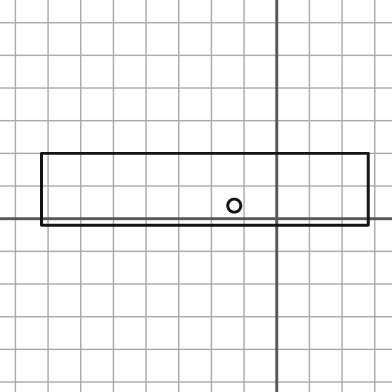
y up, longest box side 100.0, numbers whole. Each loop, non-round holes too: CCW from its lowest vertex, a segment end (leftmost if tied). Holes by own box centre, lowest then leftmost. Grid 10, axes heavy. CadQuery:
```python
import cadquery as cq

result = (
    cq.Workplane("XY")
    .moveTo(-72.0, -2.0)
    .lineTo(28.0, -2.0)
    .lineTo(28.0, 20.0)
    .lineTo(-72.0, 20.0)
    .close()
    .moveTo(-13.0, 4.0)
    .circle(2.0)
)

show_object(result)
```